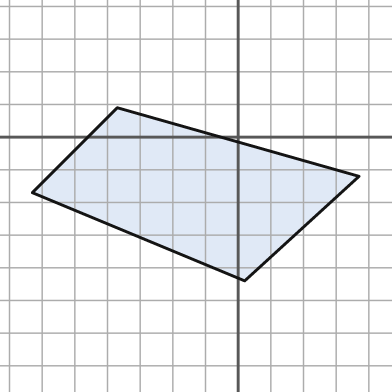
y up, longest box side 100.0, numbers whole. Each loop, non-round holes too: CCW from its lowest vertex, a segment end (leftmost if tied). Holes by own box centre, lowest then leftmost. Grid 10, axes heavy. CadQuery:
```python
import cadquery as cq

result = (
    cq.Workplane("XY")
    .moveTo(2.0, -44.0)
    .lineTo(37.0, -12.0)
    .lineTo(-37.0, 9.0)
    .lineTo(-63.0, -17.0)
    .close()
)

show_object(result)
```